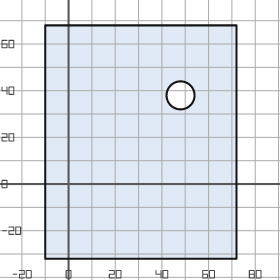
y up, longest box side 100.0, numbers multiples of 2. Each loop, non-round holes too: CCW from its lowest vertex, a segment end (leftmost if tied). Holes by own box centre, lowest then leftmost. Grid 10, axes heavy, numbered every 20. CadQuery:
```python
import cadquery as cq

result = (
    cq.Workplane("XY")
    .moveTo(-10.0, -32.0)
    .lineTo(72.0, -32.0)
    .lineTo(72.0, 68.0)
    .lineTo(-10.0, 68.0)
    .close()
    .moveTo(48.0, 38.0)
    .circle(6.0)
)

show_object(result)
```